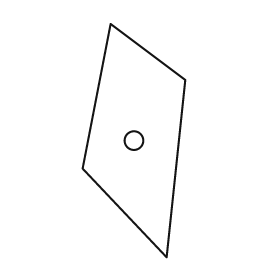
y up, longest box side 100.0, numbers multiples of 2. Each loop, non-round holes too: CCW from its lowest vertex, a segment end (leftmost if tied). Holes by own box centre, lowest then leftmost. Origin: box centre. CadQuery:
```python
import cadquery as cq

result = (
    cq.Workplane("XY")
    .moveTo(14.0, -50.0)
    .lineTo(22.0, 26.0)
    .lineTo(-10.0, 50.0)
    .lineTo(-22.0, -12.0)
    .close()
    .moveTo(0.0, 0.0)
    .circle(4.0)
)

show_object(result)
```